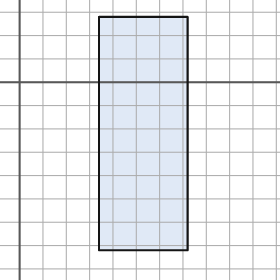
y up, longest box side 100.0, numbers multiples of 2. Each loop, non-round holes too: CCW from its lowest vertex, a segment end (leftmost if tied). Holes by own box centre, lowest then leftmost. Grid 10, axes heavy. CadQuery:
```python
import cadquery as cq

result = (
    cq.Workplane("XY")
    .moveTo(34.0, -72.0)
    .lineTo(72.0, -72.0)
    .lineTo(72.0, 28.0)
    .lineTo(34.0, 28.0)
    .close()
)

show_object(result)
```